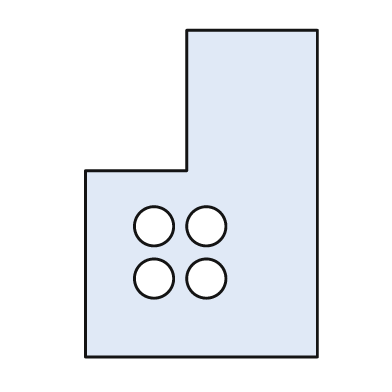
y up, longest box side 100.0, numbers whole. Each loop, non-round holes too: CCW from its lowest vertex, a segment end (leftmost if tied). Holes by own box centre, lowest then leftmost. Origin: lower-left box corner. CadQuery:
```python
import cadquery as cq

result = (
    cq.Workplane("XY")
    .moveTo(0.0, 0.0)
    .lineTo(71.0, 0.0)
    .lineTo(71.0, 100.0)
    .lineTo(31.0, 100.0)
    .lineTo(31.0, 57.0)
    .lineTo(0.0, 57.0)
    .close()
    .moveTo(21.0, 24.0)
    .circle(6.0)
    .moveTo(37.0, 24.0)
    .circle(6.0)
    .moveTo(21.0, 40.0)
    .circle(6.0)
    .moveTo(37.0, 40.0)
    .circle(6.0)
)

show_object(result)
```